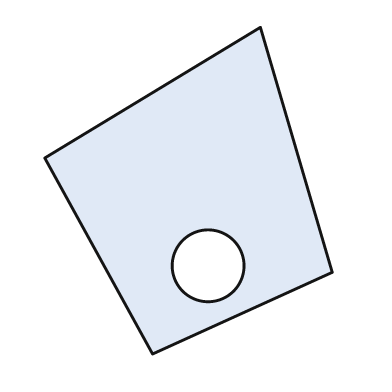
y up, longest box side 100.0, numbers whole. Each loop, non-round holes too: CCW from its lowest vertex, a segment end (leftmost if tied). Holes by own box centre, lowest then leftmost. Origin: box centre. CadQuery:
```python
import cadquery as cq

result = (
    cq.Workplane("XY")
    .moveTo(-11.0, -50.0)
    .lineTo(44.0, -25.0)
    .lineTo(22.0, 50.0)
    .lineTo(-44.0, 10.0)
    .close()
    .moveTo(6.0, -23.0)
    .circle(11.0)
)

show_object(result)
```